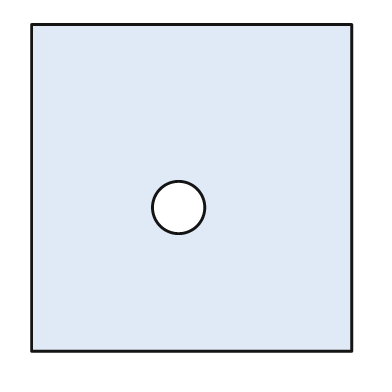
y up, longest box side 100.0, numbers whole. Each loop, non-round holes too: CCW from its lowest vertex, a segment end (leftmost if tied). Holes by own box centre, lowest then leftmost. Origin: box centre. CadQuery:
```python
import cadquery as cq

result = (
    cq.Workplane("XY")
    .moveTo(-49.0, -50.0)
    .lineTo(49.0, -50.0)
    .lineTo(49.0, 50.0)
    .lineTo(-49.0, 50.0)
    .close()
    .moveTo(-4.0, -6.0)
    .circle(8.0)
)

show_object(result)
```